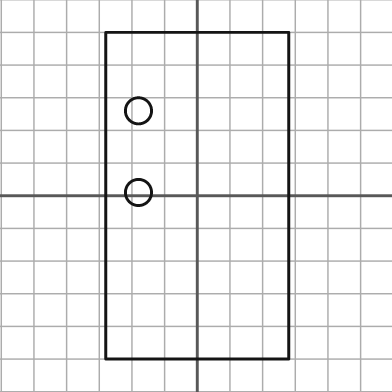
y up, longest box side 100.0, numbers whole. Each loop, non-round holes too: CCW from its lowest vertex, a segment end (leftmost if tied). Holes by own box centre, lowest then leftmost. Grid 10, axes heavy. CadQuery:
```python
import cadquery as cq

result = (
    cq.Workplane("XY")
    .moveTo(-28.0, -50.0)
    .lineTo(28.0, -50.0)
    .lineTo(28.0, 50.0)
    .lineTo(-28.0, 50.0)
    .close()
    .moveTo(-18.0, 1.0)
    .circle(4.0)
    .moveTo(-18.0, 26.0)
    .circle(4.0)
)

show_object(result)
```